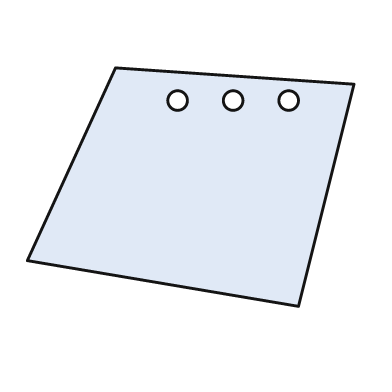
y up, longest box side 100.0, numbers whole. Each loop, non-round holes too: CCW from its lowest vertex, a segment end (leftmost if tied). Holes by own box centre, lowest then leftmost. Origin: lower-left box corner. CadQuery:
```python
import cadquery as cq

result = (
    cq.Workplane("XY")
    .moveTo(83.0, 0.0)
    .lineTo(100.0, 68.0)
    .lineTo(27.0, 73.0)
    .lineTo(0.0, 14.0)
    .close()
    .moveTo(46.0, 63.0)
    .circle(3.0)
    .moveTo(63.0, 63.0)
    .circle(3.0)
    .moveTo(80.0, 63.0)
    .circle(3.0)
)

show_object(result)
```